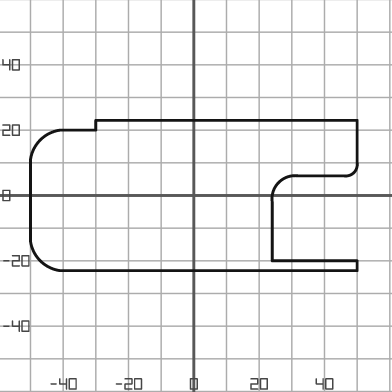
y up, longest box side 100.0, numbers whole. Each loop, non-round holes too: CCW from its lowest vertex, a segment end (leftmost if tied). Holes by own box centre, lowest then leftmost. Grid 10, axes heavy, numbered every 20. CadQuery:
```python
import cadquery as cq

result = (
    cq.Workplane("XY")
    .moveTo(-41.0, -23.0)
    .lineTo(50.0, -23.0)
    .lineTo(50.0, -20.0)
    .lineTo(24.0, -20.0)
    .lineTo(24.0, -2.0)
    .threePointArc((26.0, 4.0), (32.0, 6.0))
    .lineTo(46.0, 6.0)
    .threePointArc((49.0, 7.0), (50.0, 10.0))
    .lineTo(50.0, 23.0)
    .lineTo(-30.0, 23.0)
    .lineTo(-30.0, 20.0)
    .lineTo(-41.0, 20.0)
    .threePointArc((-47.0, 17.0), (-50.0, 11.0))
    .lineTo(-50.0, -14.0)
    .threePointArc((-47.0, -20.0), (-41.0, -23.0))
    .close()
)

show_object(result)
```